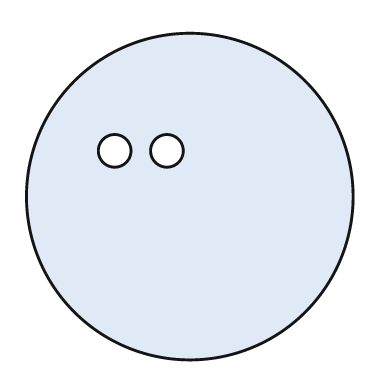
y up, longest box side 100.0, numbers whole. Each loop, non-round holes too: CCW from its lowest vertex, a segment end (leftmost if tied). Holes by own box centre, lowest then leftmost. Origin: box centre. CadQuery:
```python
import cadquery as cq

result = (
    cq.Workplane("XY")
    .moveTo(0.0, 0.0)
    .circle(50.0)
    .moveTo(-23.0, 14.0)
    .circle(5.0)
    .moveTo(-7.0, 14.0)
    .circle(5.0)
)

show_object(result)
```